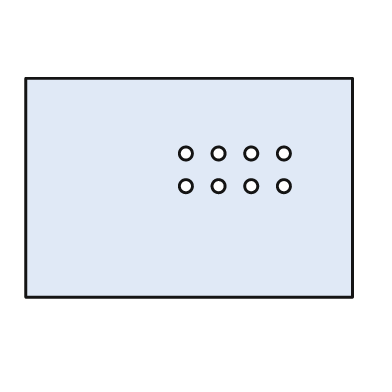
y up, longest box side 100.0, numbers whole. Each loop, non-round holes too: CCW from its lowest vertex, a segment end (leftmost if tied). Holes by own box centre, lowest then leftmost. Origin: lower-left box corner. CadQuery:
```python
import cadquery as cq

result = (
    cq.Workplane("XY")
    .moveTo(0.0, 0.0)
    .lineTo(100.0, 0.0)
    .lineTo(100.0, 67.0)
    .lineTo(0.0, 67.0)
    .close()
    .moveTo(49.0, 34.0)
    .circle(2.0)
    .moveTo(59.0, 34.0)
    .circle(2.0)
    .moveTo(69.0, 34.0)
    .circle(2.0)
    .moveTo(79.0, 34.0)
    .circle(2.0)
    .moveTo(49.0, 44.0)
    .circle(2.0)
    .moveTo(59.0, 44.0)
    .circle(2.0)
    .moveTo(69.0, 44.0)
    .circle(2.0)
    .moveTo(79.0, 44.0)
    .circle(2.0)
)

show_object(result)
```